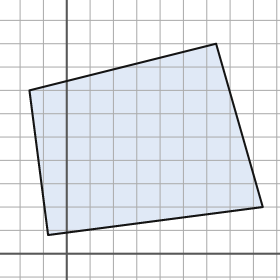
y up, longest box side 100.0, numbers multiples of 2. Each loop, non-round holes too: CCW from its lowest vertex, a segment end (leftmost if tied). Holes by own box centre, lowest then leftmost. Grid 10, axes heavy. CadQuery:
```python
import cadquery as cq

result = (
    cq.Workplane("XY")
    .moveTo(-8.0, 8.0)
    .lineTo(84.0, 20.0)
    .lineTo(64.0, 90.0)
    .lineTo(-16.0, 70.0)
    .close()
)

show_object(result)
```